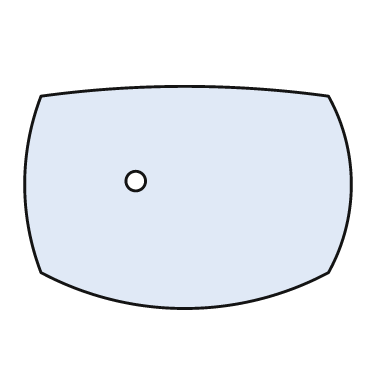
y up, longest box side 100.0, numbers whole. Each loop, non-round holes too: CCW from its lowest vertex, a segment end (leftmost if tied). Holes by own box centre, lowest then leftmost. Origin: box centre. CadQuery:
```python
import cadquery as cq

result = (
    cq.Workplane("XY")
    .moveTo(-45.0, -23.0)
    .threePointArc((-1.0, -34.0), (43.0, -23.0))
    .threePointArc((50.0, 4.0), (43.0, 31.0))
    .threePointArc((-1.0, 34.0), (-45.0, 31.0))
    .threePointArc((-50.0, 4.0), (-45.0, -23.0))
    .close()
    .moveTo(-16.0, 5.0)
    .circle(3.0)
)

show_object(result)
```